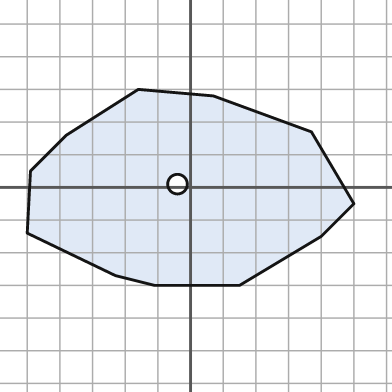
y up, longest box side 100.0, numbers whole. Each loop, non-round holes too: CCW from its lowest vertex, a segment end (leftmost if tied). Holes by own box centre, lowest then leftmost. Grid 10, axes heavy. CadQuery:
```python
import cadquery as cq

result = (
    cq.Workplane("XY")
    .moveTo(-11.0, -30.0)
    .lineTo(15.0, -30.0)
    .lineTo(40.0, -15.0)
    .lineTo(50.0, -5.0)
    .lineTo(37.0, 17.0)
    .lineTo(7.0, 28.0)
    .lineTo(-16.0, 30.0)
    .lineTo(-38.0, 16.0)
    .lineTo(-49.0, 5.0)
    .lineTo(-50.0, -14.0)
    .lineTo(-23.0, -27.0)
    .close()
    .moveTo(-4.0, 1.0)
    .circle(3.0)
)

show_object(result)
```